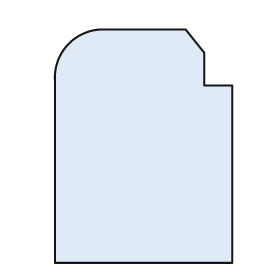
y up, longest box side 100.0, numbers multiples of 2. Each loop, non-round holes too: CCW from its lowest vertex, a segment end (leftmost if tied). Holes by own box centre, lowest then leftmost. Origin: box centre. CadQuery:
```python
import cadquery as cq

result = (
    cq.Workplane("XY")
    .moveTo(-38.0, -50.0)
    .lineTo(38.0, -50.0)
    .lineTo(38.0, 26.0)
    .lineTo(26.0, 26.0)
    .lineTo(26.0, 40.0)
    .lineTo(18.0, 50.0)
    .lineTo(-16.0, 50.0)
    .threePointArc((-32.0, 44.0), (-38.0, 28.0))
    .close()
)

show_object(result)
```